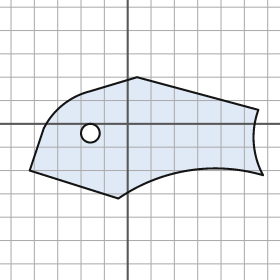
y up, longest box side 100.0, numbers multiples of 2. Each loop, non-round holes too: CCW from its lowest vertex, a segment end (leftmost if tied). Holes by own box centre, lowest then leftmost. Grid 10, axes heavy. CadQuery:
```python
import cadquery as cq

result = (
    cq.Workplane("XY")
    .moveTo(-4.0, -32.0)
    .threePointArc((26.0, -20.0), (58.0, -22.0))
    .threePointArc((54.0, -8.0), (56.0, 6.0))
    .lineTo(4.0, 20.0)
    .lineTo(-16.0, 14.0)
    .threePointArc((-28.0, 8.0), (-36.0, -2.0))
    .lineTo(-42.0, -20.0)
    .close()
    .moveTo(-16.0, -4.0)
    .circle(4.0)
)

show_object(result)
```